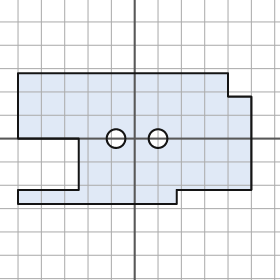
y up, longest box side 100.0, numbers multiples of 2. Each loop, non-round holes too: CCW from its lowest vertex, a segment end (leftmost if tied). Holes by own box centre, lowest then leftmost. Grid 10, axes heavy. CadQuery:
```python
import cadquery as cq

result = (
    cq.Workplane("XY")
    .moveTo(-50.0, -28.0)
    .lineTo(18.0, -28.0)
    .lineTo(18.0, -22.0)
    .lineTo(50.0, -22.0)
    .lineTo(50.0, 18.0)
    .lineTo(40.0, 18.0)
    .lineTo(40.0, 28.0)
    .lineTo(-50.0, 28.0)
    .lineTo(-50.0, 0.0)
    .lineTo(-24.0, 0.0)
    .lineTo(-24.0, -22.0)
    .lineTo(-50.0, -22.0)
    .close()
    .moveTo(-8.0, 0.0)
    .circle(4.0)
    .moveTo(10.0, 0.0)
    .circle(4.0)
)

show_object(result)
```